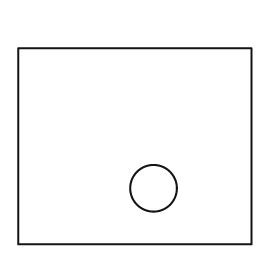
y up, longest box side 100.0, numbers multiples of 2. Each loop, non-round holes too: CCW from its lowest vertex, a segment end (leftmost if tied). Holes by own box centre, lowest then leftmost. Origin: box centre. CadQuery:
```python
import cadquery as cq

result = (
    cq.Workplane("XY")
    .moveTo(-50.0, -42.0)
    .lineTo(50.0, -42.0)
    .lineTo(50.0, 42.0)
    .lineTo(-50.0, 42.0)
    .close()
    .moveTo(8.0, -18.0)
    .circle(10.0)
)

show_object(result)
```